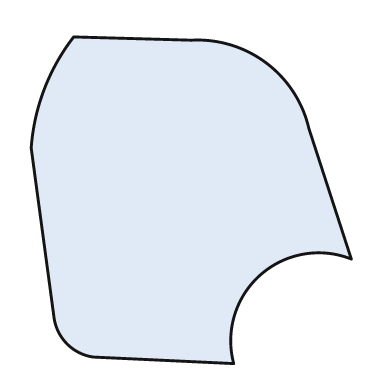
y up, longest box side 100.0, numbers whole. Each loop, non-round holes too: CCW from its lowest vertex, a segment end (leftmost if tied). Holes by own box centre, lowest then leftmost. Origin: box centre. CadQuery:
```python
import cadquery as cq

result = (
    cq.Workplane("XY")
    .moveTo(13.0, -50.0)
    .threePointArc((21.0, -23.0), (49.0, -18.0))
    .lineTo(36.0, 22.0)
    .threePointArc((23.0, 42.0), (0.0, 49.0))
    .lineTo(-36.0, 50.0)
    .threePointArc((-45.0, 34.0), (-49.0, 16.0))
    .lineTo(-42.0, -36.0)
    .threePointArc((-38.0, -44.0), (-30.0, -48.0))
    .close()
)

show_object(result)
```